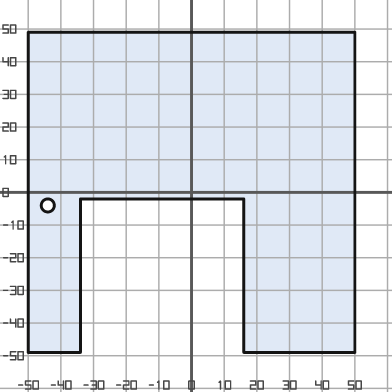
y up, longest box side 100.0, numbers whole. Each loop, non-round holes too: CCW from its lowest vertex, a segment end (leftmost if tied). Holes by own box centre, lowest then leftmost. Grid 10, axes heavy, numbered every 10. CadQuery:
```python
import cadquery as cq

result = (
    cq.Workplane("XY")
    .moveTo(-50.0, -49.0)
    .lineTo(-34.0, -49.0)
    .lineTo(-34.0, -2.0)
    .lineTo(16.0, -2.0)
    .lineTo(16.0, -49.0)
    .lineTo(50.0, -49.0)
    .lineTo(50.0, 49.0)
    .lineTo(-50.0, 49.0)
    .close()
    .moveTo(-44.0, -4.0)
    .circle(2.0)
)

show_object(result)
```